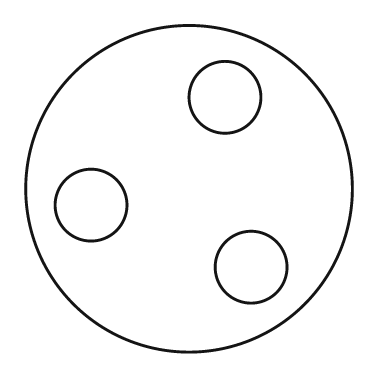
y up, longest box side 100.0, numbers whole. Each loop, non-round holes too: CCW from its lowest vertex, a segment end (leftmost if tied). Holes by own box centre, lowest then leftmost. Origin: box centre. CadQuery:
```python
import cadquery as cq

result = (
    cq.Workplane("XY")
    .moveTo(0.0, 0.0)
    .circle(50.0)
    .moveTo(19.0, -24.0)
    .circle(11.0)
    .moveTo(-30.0, -5.0)
    .circle(11.0)
    .moveTo(11.0, 28.0)
    .circle(11.0)
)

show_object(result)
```